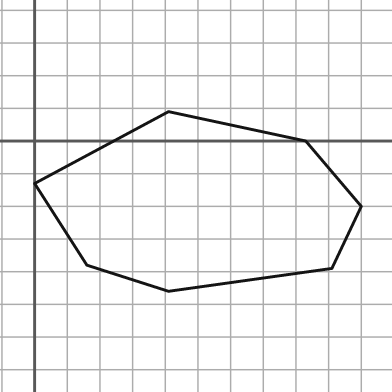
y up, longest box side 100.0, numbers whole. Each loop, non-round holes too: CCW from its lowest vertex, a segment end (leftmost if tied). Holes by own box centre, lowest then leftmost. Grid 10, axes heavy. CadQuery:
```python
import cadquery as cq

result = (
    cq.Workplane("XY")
    .moveTo(41.0, -46.0)
    .lineTo(91.0, -39.0)
    .lineTo(100.0, -20.0)
    .lineTo(83.0, 0.0)
    .lineTo(41.0, 9.0)
    .lineTo(0.0, -13.0)
    .lineTo(16.0, -38.0)
    .close()
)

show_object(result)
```